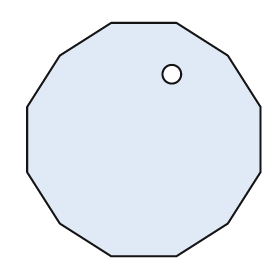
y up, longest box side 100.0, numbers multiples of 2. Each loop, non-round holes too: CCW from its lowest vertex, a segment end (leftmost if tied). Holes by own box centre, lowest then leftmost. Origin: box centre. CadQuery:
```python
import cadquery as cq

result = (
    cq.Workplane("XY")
    .moveTo(-14.0, -50.0)
    .lineTo(14.0, -50.0)
    .lineTo(36.0, -36.0)
    .lineTo(50.0, -14.0)
    .lineTo(50.0, 14.0)
    .lineTo(36.0, 36.0)
    .lineTo(14.0, 50.0)
    .lineTo(-14.0, 50.0)
    .lineTo(-36.0, 36.0)
    .lineTo(-50.0, 14.0)
    .lineTo(-50.0, -14.0)
    .lineTo(-36.0, -36.0)
    .close()
    .moveTo(12.0, 28.0)
    .circle(4.0)
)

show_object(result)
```